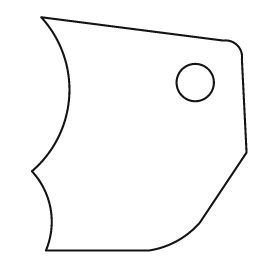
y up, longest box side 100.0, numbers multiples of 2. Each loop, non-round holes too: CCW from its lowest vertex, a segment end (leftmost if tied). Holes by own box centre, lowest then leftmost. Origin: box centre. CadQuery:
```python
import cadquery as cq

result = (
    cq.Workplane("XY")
    .moveTo(-40.0, -50.0)
    .lineTo(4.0, -50.0)
    .threePointArc((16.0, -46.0), (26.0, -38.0))
    .lineTo(46.0, -8.0)
    .lineTo(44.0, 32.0)
    .threePointArc((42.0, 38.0), (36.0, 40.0))
    .lineTo(-42.0, 50.0)
    .threePointArc((-30.0, 16.0), (-46.0, -16.0))
    .threePointArc((-38.0, -32.0), (-40.0, -50.0))
    .close()
    .moveTo(24.0, 22.0)
    .circle(8.0)
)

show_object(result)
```